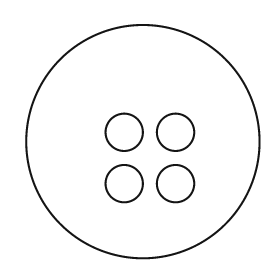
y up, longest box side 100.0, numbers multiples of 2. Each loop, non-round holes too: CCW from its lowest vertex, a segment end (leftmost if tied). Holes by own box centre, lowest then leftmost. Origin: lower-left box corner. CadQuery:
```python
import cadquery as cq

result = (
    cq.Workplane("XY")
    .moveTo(50.0, 50.0)
    .circle(50.0)
    .moveTo(42.0, 32.0)
    .circle(8.0)
    .moveTo(64.0, 32.0)
    .circle(8.0)
    .moveTo(42.0, 54.0)
    .circle(8.0)
    .moveTo(64.0, 54.0)
    .circle(8.0)
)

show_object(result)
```